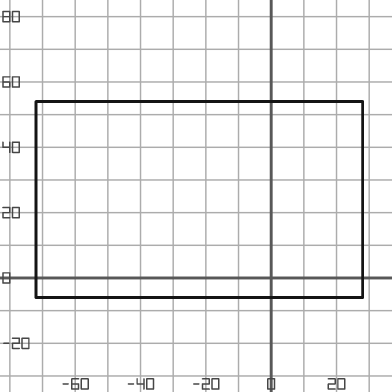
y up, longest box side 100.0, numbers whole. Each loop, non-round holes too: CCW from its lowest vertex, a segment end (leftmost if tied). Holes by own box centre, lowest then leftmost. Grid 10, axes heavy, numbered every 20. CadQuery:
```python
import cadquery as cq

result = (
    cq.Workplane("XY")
    .moveTo(-72.0, -6.0)
    .lineTo(28.0, -6.0)
    .lineTo(28.0, 54.0)
    .lineTo(-72.0, 54.0)
    .close()
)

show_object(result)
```